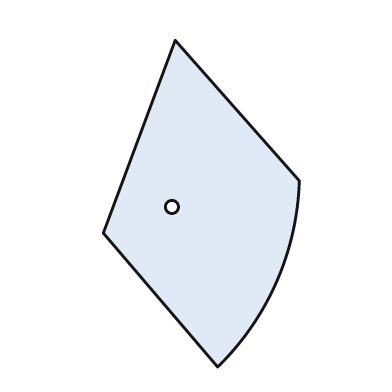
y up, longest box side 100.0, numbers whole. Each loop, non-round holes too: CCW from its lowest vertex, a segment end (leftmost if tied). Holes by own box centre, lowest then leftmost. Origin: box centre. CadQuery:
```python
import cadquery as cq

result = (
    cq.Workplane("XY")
    .moveTo(5.0, -50.0)
    .threePointArc((23.0, -24.0), (30.0, 7.0))
    .lineTo(-8.0, 50.0)
    .lineTo(-30.0, -9.0)
    .close()
    .moveTo(-9.0, -1.0)
    .circle(2.0)
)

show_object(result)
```